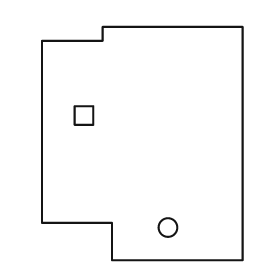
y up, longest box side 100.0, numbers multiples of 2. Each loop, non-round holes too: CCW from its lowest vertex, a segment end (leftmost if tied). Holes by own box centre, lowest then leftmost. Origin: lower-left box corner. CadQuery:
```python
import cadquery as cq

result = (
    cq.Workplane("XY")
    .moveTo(30.0, 0.0)
    .lineTo(86.0, 0.0)
    .lineTo(86.0, 100.0)
    .lineTo(26.0, 100.0)
    .lineTo(26.0, 94.0)
    .lineTo(0.0, 94.0)
    .lineTo(0.0, 16.0)
    .lineTo(30.0, 16.0)
    .close()
    .moveTo(54.0, 14.0)
    .circle(4.0)
    .moveTo(14.0, 58.0)
    .lineTo(22.0, 58.0)
    .lineTo(22.0, 66.0)
    .lineTo(14.0, 66.0)
    .close()
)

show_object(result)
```